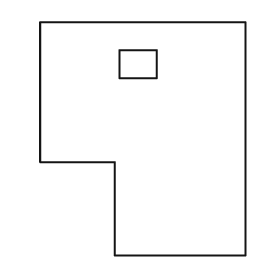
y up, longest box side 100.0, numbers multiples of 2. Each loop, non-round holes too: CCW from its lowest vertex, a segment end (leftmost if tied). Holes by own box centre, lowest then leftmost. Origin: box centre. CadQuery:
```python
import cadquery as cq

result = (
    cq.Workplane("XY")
    .moveTo(-12.0, -50.0)
    .lineTo(44.0, -50.0)
    .lineTo(44.0, 50.0)
    .lineTo(-44.0, 50.0)
    .lineTo(-44.0, -10.0)
    .lineTo(-12.0, -10.0)
    .close()
    .moveTo(-10.0, 26.0)
    .lineTo(6.0, 26.0)
    .lineTo(6.0, 38.0)
    .lineTo(-10.0, 38.0)
    .close()
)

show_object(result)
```